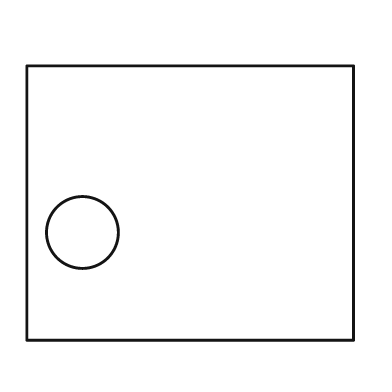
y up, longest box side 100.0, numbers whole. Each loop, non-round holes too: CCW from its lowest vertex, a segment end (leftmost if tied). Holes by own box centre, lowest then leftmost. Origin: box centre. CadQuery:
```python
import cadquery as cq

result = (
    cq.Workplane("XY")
    .moveTo(-50.0, -42.0)
    .lineTo(50.0, -42.0)
    .lineTo(50.0, 42.0)
    .lineTo(-50.0, 42.0)
    .close()
    .moveTo(-33.0, -9.0)
    .circle(11.0)
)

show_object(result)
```